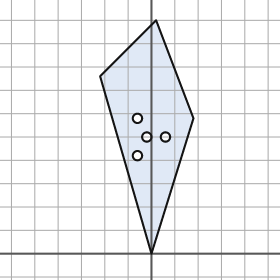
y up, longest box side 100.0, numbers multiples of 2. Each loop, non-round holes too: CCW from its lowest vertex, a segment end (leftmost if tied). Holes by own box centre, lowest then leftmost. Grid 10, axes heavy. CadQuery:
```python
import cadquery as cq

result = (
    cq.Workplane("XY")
    .moveTo(0.0, 0.0)
    .lineTo(18.0, 58.0)
    .lineTo(2.0, 100.0)
    .lineTo(-22.0, 76.0)
    .close()
    .moveTo(-6.0, 42.0)
    .circle(2.0)
    .moveTo(-2.0, 50.0)
    .circle(2.0)
    .moveTo(6.0, 50.0)
    .circle(2.0)
    .moveTo(-6.0, 58.0)
    .circle(2.0)
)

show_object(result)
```